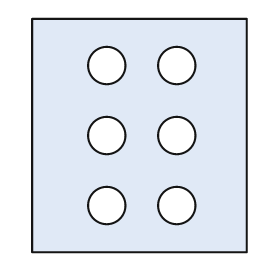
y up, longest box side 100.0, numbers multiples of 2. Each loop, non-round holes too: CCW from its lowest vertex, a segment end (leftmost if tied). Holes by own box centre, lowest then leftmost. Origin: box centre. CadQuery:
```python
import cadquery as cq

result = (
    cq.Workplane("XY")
    .moveTo(-46.0, -50.0)
    .lineTo(46.0, -50.0)
    .lineTo(46.0, 50.0)
    .lineTo(-46.0, 50.0)
    .close()
    .moveTo(-14.0, -30.0)
    .circle(8.0)
    .moveTo(16.0, -30.0)
    .circle(8.0)
    .moveTo(-14.0, 0.0)
    .circle(8.0)
    .moveTo(16.0, 0.0)
    .circle(8.0)
    .moveTo(-14.0, 30.0)
    .circle(8.0)
    .moveTo(16.0, 30.0)
    .circle(8.0)
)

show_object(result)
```